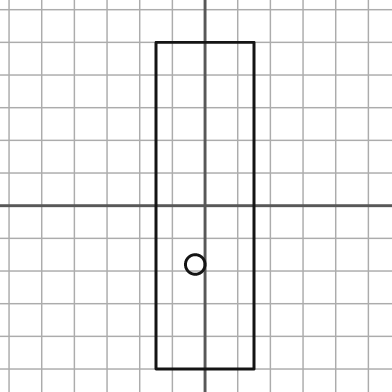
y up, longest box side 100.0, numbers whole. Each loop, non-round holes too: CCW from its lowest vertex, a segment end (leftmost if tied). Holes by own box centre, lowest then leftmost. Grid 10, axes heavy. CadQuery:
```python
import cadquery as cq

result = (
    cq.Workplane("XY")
    .moveTo(-15.0, -50.0)
    .lineTo(15.0, -50.0)
    .lineTo(15.0, 50.0)
    .lineTo(-15.0, 50.0)
    .close()
    .moveTo(-3.0, -18.0)
    .circle(3.0)
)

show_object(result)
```